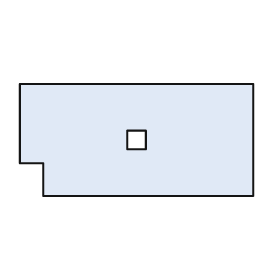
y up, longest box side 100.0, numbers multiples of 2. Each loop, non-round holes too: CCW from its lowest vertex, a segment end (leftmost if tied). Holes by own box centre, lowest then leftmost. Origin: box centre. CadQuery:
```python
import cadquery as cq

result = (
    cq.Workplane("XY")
    .moveTo(-40.0, -24.0)
    .lineTo(50.0, -24.0)
    .lineTo(50.0, 24.0)
    .lineTo(-50.0, 24.0)
    .lineTo(-50.0, -10.0)
    .lineTo(-40.0, -10.0)
    .close()
    .moveTo(-4.0, -4.0)
    .lineTo(4.0, -4.0)
    .lineTo(4.0, 4.0)
    .lineTo(-4.0, 4.0)
    .close()
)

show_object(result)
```